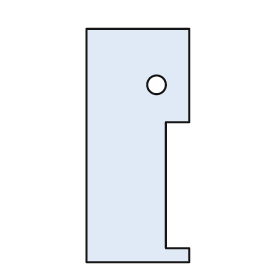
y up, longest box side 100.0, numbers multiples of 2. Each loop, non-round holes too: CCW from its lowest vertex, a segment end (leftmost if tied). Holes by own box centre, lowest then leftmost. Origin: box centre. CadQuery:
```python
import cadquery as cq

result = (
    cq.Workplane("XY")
    .moveTo(-22.0, -50.0)
    .lineTo(22.0, -50.0)
    .lineTo(22.0, -44.0)
    .lineTo(12.0, -44.0)
    .lineTo(12.0, 10.0)
    .lineTo(22.0, 10.0)
    .lineTo(22.0, 50.0)
    .lineTo(-22.0, 50.0)
    .close()
    .moveTo(8.0, 26.0)
    .circle(4.0)
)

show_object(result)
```